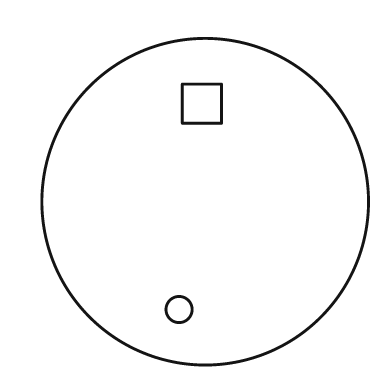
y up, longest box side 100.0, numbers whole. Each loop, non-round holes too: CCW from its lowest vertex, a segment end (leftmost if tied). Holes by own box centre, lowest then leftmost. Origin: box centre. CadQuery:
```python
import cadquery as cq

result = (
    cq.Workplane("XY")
    .moveTo(0.0, 0.0)
    .circle(50.0)
    .moveTo(-8.0, -33.0)
    .circle(4.0)
    .moveTo(-7.0, 24.0)
    .lineTo(5.0, 24.0)
    .lineTo(5.0, 36.0)
    .lineTo(-7.0, 36.0)
    .close()
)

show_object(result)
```